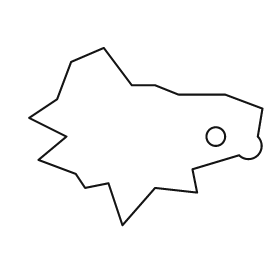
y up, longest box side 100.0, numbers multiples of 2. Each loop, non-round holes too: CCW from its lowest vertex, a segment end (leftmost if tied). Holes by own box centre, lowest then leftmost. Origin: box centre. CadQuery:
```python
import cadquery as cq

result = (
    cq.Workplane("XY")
    .moveTo(-10.0, -38.0)
    .lineTo(4.0, -22.0)
    .lineTo(22.0, -24.0)
    .lineTo(20.0, -14.0)
    .lineTo(40.0, -8.0)
    .threePointArc((48.0, -8.0), (48.0, 0.0))
    .lineTo(50.0, 12.0)
    .lineTo(34.0, 18.0)
    .lineTo(14.0, 18.0)
    .lineTo(4.0, 22.0)
    .lineTo(-6.0, 22.0)
    .lineTo(-18.0, 38.0)
    .lineTo(-32.0, 32.0)
    .lineTo(-38.0, 16.0)
    .lineTo(-50.0, 8.0)
    .lineTo(-34.0, 0.0)
    .lineTo(-46.0, -10.0)
    .lineTo(-30.0, -16.0)
    .lineTo(-26.0, -22.0)
    .lineTo(-16.0, -20.0)
    .close()
    .moveTo(30.0, 0.0)
    .circle(4.0)
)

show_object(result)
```